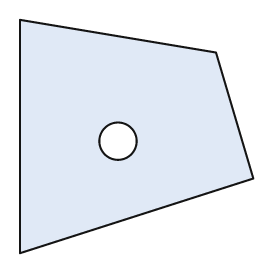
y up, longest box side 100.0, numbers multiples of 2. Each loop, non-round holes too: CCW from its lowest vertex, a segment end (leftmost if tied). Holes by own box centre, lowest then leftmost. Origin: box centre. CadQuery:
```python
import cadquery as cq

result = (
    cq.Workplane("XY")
    .moveTo(-50.0, -50.0)
    .lineTo(50.0, -18.0)
    .lineTo(34.0, 36.0)
    .lineTo(-50.0, 50.0)
    .close()
    .moveTo(-8.0, -2.0)
    .circle(8.0)
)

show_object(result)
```